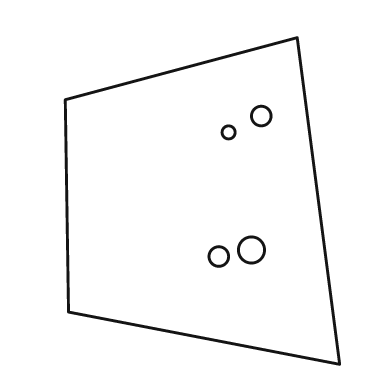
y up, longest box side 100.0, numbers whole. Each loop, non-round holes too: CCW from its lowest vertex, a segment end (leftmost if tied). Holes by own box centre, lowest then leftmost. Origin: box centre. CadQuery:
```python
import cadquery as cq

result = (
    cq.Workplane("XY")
    .moveTo(42.0, -50.0)
    .lineTo(29.0, 50.0)
    .lineTo(-42.0, 31.0)
    .lineTo(-41.0, -34.0)
    .close()
    .moveTo(5.0, -17.0)
    .circle(3.0)
    .moveTo(15.0, -15.0)
    .circle(4.0)
    .moveTo(8.0, 21.0)
    .circle(2.0)
    .moveTo(18.0, 26.0)
    .circle(3.0)
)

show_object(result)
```